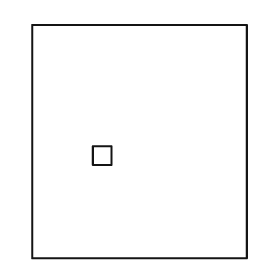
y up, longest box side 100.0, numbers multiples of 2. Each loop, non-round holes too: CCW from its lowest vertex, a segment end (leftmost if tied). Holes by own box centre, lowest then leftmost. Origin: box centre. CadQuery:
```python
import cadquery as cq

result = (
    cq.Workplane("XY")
    .moveTo(-46.0, -50.0)
    .lineTo(46.0, -50.0)
    .lineTo(46.0, 50.0)
    .lineTo(-46.0, 50.0)
    .close()
    .moveTo(-20.0, -10.0)
    .lineTo(-12.0, -10.0)
    .lineTo(-12.0, -2.0)
    .lineTo(-20.0, -2.0)
    .close()
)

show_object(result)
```